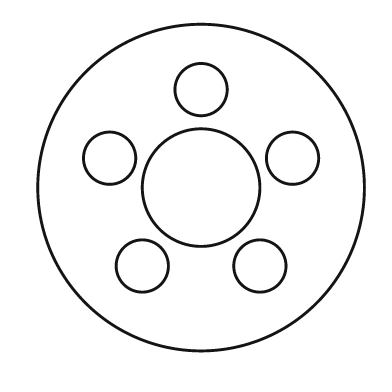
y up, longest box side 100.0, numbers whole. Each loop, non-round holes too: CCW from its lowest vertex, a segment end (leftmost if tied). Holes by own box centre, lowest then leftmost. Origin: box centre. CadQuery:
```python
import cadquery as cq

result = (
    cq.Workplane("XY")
    .moveTo(0.0, 0.0)
    .circle(50.0)
    .moveTo(-18.0, -24.0)
    .circle(8.0)
    .moveTo(18.0, -24.0)
    .circle(8.0)
    .moveTo(0.0, 0.0)
    .circle(18.0)
    .moveTo(-28.0, 9.0)
    .circle(8.0)
    .moveTo(28.0, 9.0)
    .circle(8.0)
    .moveTo(0.0, 30.0)
    .circle(8.0)
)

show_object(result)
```